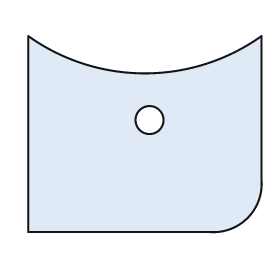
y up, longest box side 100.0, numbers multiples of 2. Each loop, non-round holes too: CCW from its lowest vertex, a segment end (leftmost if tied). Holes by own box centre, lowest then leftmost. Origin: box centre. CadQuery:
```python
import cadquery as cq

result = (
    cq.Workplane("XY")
    .moveTo(-50.0, -42.0)
    .lineTo(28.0, -42.0)
    .threePointArc((44.0, -36.0), (50.0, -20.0))
    .lineTo(50.0, 42.0)
    .threePointArc((0.0, 26.0), (-50.0, 42.0))
    .close()
    .moveTo(2.0, 6.0)
    .circle(6.0)
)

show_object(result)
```